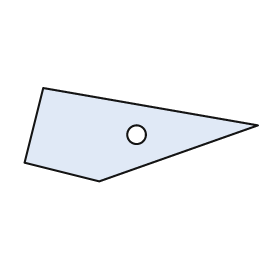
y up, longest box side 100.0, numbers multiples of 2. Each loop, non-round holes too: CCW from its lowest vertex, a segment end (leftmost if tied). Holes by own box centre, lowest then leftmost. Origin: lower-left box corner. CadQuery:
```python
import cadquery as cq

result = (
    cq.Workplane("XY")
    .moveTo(32.0, 0.0)
    .lineTo(100.0, 24.0)
    .lineTo(8.0, 40.0)
    .lineTo(0.0, 8.0)
    .close()
    .moveTo(48.0, 20.0)
    .circle(4.0)
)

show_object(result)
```